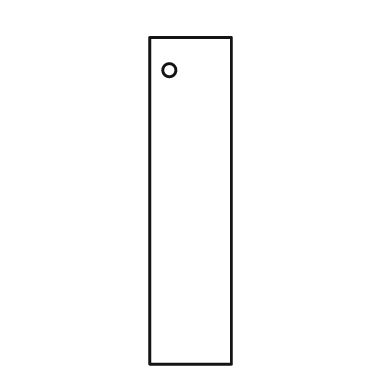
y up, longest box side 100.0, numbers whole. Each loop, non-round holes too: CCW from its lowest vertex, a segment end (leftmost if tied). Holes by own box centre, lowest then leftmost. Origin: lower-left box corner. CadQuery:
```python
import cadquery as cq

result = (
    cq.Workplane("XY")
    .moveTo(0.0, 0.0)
    .lineTo(25.0, 0.0)
    .lineTo(25.0, 100.0)
    .lineTo(0.0, 100.0)
    .close()
    .moveTo(6.0, 90.0)
    .circle(2.0)
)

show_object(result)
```